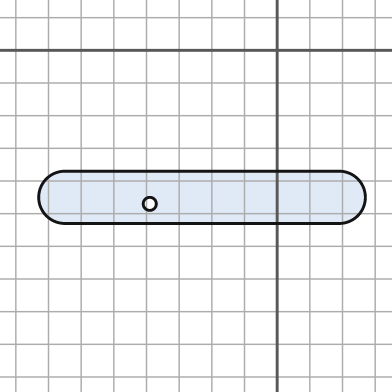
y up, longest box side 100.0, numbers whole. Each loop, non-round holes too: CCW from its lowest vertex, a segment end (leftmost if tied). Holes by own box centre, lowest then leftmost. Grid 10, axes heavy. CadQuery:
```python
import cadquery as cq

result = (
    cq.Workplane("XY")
    .moveTo(-65.0, -53.0)
    .lineTo(19.0, -53.0)
    .threePointArc((27.0, -45.0), (19.0, -37.0))
    .lineTo(-65.0, -37.0)
    .threePointArc((-73.0, -45.0), (-65.0, -53.0))
    .close()
    .moveTo(-39.0, -47.0)
    .circle(2.0)
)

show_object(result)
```